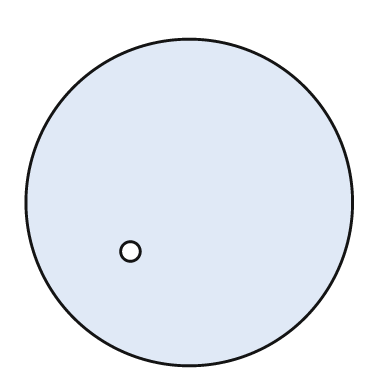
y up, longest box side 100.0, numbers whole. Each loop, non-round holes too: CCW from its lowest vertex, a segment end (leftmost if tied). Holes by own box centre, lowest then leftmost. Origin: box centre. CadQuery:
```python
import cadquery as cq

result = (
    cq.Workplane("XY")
    .moveTo(0.0, 0.0)
    .circle(50.0)
    .moveTo(-18.0, -15.0)
    .circle(3.0)
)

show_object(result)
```